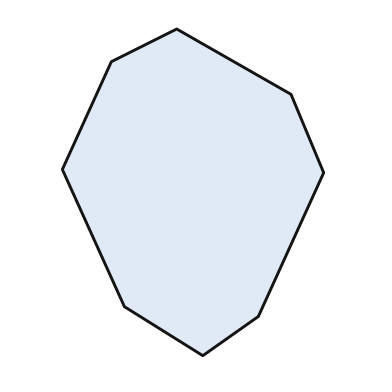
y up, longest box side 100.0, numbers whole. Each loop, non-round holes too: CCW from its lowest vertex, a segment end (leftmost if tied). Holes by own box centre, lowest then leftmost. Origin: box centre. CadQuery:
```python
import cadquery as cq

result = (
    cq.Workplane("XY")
    .moveTo(3.0, -50.0)
    .lineTo(20.0, -38.0)
    .lineTo(40.0, 6.0)
    .lineTo(30.0, 30.0)
    .lineTo(-5.0, 50.0)
    .lineTo(-25.0, 40.0)
    .lineTo(-40.0, 7.0)
    .lineTo(-21.0, -35.0)
    .close()
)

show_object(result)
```